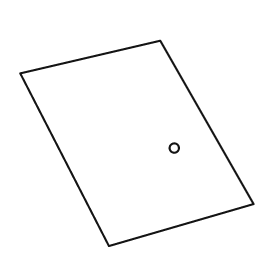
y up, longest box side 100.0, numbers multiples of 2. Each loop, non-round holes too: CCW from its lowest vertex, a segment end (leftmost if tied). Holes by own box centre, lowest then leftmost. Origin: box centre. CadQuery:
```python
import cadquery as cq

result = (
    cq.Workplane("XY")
    .moveTo(-12.0, -44.0)
    .lineTo(50.0, -26.0)
    .lineTo(10.0, 44.0)
    .lineTo(-50.0, 30.0)
    .close()
    .moveTo(16.0, -2.0)
    .circle(2.0)
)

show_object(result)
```